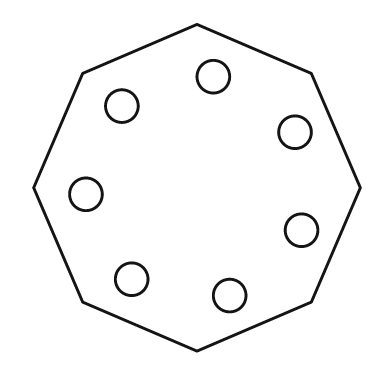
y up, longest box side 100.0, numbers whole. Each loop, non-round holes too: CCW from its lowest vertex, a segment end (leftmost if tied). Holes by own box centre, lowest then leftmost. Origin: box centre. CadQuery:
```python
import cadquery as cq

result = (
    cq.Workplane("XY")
    .moveTo(0.0, -50.0)
    .lineTo(35.0, -35.0)
    .lineTo(50.0, 0.0)
    .lineTo(35.0, 35.0)
    .lineTo(0.0, 50.0)
    .lineTo(-35.0, 35.0)
    .lineTo(-50.0, 0.0)
    .lineTo(-35.0, -35.0)
    .close()
    .moveTo(10.0, -33.0)
    .circle(5.0)
    .moveTo(-20.0, -28.0)
    .circle(5.0)
    .moveTo(32.0, -13.0)
    .circle(5.0)
    .moveTo(-34.0, -2.0)
    .circle(5.0)
    .moveTo(30.0, 17.0)
    .circle(5.0)
    .moveTo(-23.0, 25.0)
    .circle(5.0)
    .moveTo(5.0, 34.0)
    .circle(5.0)
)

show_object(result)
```